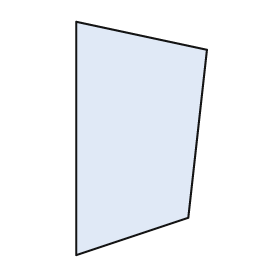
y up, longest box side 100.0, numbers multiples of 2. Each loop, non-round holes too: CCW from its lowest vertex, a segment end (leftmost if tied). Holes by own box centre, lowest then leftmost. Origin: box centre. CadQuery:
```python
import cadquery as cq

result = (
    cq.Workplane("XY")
    .moveTo(-28.0, -50.0)
    .lineTo(20.0, -34.0)
    .lineTo(28.0, 38.0)
    .lineTo(-28.0, 50.0)
    .close()
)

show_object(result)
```